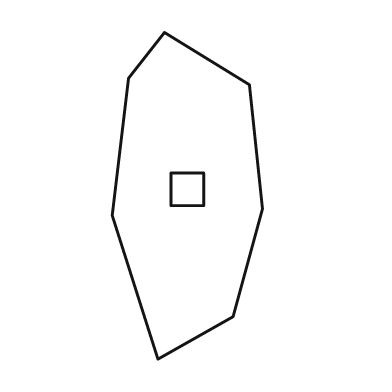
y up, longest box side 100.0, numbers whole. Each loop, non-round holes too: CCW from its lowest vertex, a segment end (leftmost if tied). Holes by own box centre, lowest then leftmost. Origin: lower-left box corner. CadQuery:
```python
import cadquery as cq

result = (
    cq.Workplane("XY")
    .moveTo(14.0, 0.0)
    .lineTo(37.0, 13.0)
    .lineTo(46.0, 46.0)
    .lineTo(42.0, 84.0)
    .lineTo(16.0, 100.0)
    .lineTo(5.0, 86.0)
    .lineTo(0.0, 44.0)
    .close()
    .moveTo(18.0, 47.0)
    .lineTo(28.0, 47.0)
    .lineTo(28.0, 57.0)
    .lineTo(18.0, 57.0)
    .close()
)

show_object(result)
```